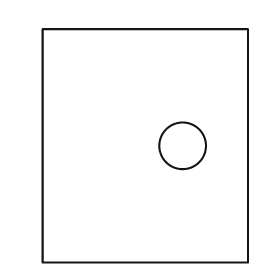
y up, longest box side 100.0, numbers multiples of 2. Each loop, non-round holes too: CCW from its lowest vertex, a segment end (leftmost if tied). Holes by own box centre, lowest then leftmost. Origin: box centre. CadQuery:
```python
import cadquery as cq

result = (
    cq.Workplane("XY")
    .moveTo(-44.0, -50.0)
    .lineTo(44.0, -50.0)
    .lineTo(44.0, 50.0)
    .lineTo(-44.0, 50.0)
    .close()
    .moveTo(16.0, 0.0)
    .circle(10.0)
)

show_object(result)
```